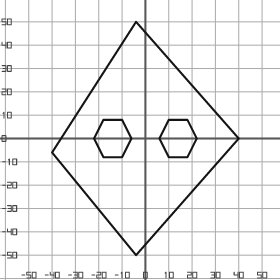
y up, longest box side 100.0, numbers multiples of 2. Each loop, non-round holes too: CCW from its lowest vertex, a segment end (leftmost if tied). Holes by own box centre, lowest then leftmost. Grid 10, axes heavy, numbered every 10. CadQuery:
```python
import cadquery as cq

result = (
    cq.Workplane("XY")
    .moveTo(-4.0, -50.0)
    .lineTo(40.0, 0.0)
    .lineTo(-4.0, 50.0)
    .lineTo(-40.0, -6.0)
    .close()
    .moveTo(-18.0, -8.0)
    .lineTo(-10.0, -8.0)
    .lineTo(-6.0, 0.0)
    .lineTo(-10.0, 8.0)
    .lineTo(-18.0, 8.0)
    .lineTo(-22.0, 0.0)
    .close()
    .moveTo(10.0, -8.0)
    .lineTo(18.0, -8.0)
    .lineTo(22.0, 0.0)
    .lineTo(18.0, 8.0)
    .lineTo(10.0, 8.0)
    .lineTo(6.0, 0.0)
    .close()
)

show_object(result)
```